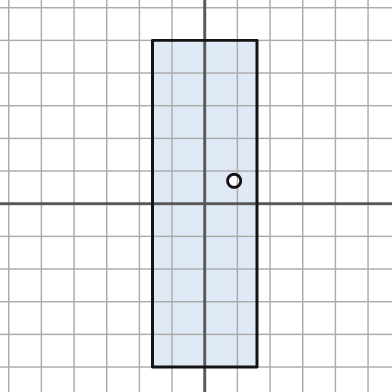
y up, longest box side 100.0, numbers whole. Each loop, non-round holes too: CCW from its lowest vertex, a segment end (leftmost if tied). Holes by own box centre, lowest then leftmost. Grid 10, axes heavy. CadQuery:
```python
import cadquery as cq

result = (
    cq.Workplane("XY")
    .moveTo(-16.0, -50.0)
    .lineTo(16.0, -50.0)
    .lineTo(16.0, 50.0)
    .lineTo(-16.0, 50.0)
    .close()
    .moveTo(9.0, 7.0)
    .circle(2.0)
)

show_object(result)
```